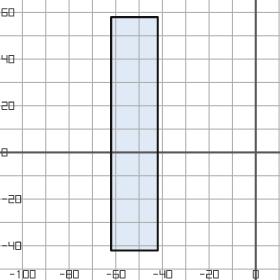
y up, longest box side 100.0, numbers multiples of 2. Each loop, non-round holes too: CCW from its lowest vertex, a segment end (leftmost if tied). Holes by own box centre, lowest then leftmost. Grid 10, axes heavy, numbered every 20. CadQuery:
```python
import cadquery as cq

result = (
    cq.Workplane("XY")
    .moveTo(-62.0, -42.0)
    .lineTo(-42.0, -42.0)
    .lineTo(-42.0, 58.0)
    .lineTo(-62.0, 58.0)
    .close()
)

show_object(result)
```